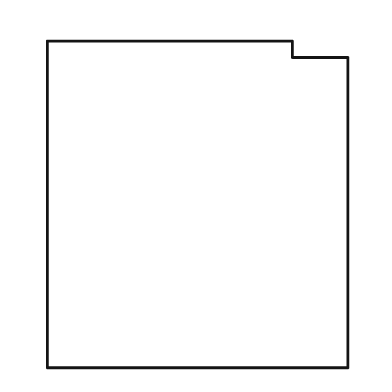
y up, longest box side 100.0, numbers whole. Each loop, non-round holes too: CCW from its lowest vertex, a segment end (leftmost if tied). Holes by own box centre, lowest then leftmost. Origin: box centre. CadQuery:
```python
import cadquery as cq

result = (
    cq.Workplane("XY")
    .moveTo(-46.0, -50.0)
    .lineTo(46.0, -50.0)
    .lineTo(46.0, 45.0)
    .lineTo(29.0, 45.0)
    .lineTo(29.0, 50.0)
    .lineTo(-46.0, 50.0)
    .close()
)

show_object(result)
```